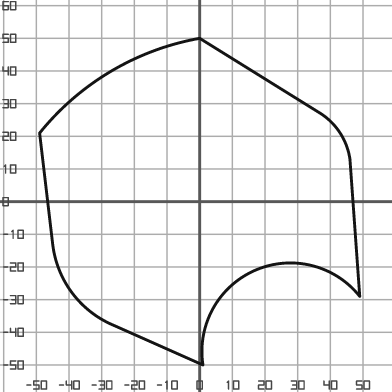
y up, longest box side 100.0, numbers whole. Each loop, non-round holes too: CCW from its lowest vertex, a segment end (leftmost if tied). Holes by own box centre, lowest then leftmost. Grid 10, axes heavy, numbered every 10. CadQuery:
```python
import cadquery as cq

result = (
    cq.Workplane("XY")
    .moveTo(1.0, -50.0)
    .threePointArc((17.0, -21.0), (49.0, -29.0))
    .lineTo(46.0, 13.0)
    .threePointArc((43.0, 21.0), (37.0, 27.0))
    .lineTo(0.0, 50.0)
    .threePointArc((-27.0, 40.0), (-49.0, 21.0))
    .lineTo(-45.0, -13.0)
    .threePointArc((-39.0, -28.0), (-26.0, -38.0))
    .close()
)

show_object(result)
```